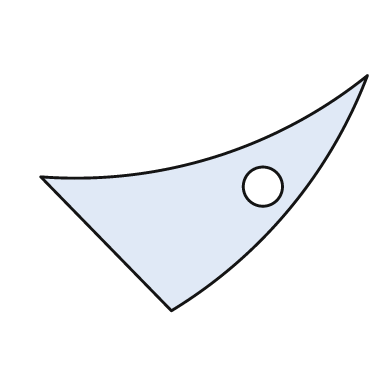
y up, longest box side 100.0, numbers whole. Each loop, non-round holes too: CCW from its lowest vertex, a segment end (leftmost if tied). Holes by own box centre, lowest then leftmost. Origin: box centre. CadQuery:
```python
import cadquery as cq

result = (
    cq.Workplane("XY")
    .moveTo(-10.0, -36.0)
    .threePointArc((26.0, -5.0), (50.0, 36.0))
    .threePointArc((3.0, 11.0), (-50.0, 5.0))
    .close()
    .moveTo(18.0, 2.0)
    .circle(6.0)
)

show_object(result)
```